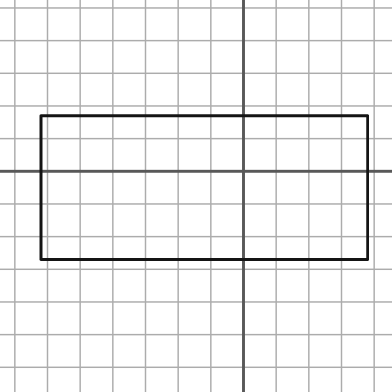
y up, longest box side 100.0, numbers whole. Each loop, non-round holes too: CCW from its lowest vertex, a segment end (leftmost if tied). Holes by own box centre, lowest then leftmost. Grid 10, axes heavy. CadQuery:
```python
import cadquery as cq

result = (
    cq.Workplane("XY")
    .moveTo(-62.0, -27.0)
    .lineTo(38.0, -27.0)
    .lineTo(38.0, 17.0)
    .lineTo(-62.0, 17.0)
    .close()
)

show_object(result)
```